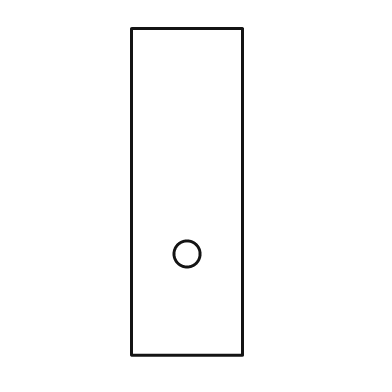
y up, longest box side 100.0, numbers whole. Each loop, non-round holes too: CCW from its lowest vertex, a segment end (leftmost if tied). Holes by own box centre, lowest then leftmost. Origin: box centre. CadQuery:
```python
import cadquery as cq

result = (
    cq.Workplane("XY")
    .moveTo(-17.0, -50.0)
    .lineTo(17.0, -50.0)
    .lineTo(17.0, 50.0)
    .lineTo(-17.0, 50.0)
    .close()
    .moveTo(0.0, -19.0)
    .circle(4.0)
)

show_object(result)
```